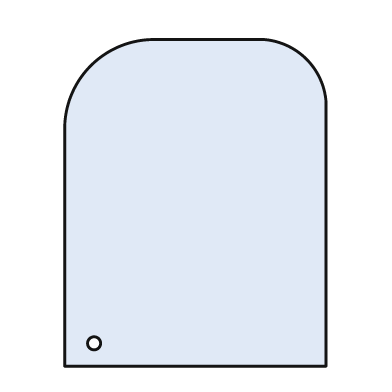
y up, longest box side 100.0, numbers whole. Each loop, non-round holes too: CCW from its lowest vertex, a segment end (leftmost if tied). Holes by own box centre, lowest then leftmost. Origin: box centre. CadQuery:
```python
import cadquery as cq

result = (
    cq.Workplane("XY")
    .moveTo(-40.0, -50.0)
    .lineTo(40.0, -50.0)
    .lineTo(40.0, 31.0)
    .threePointArc((34.0, 44.0), (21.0, 50.0))
    .lineTo(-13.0, 50.0)
    .threePointArc((-32.0, 42.0), (-40.0, 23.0))
    .close()
    .moveTo(-31.0, -43.0)
    .circle(2.0)
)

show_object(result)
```